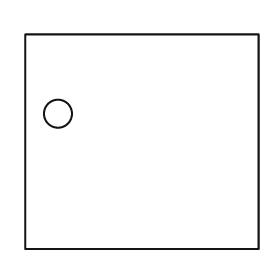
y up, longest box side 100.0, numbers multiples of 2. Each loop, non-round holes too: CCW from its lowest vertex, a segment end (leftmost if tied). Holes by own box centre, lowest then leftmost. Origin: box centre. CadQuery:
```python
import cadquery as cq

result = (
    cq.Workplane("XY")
    .moveTo(-50.0, -46.0)
    .lineTo(50.0, -46.0)
    .lineTo(50.0, 46.0)
    .lineTo(-50.0, 46.0)
    .close()
    .moveTo(-36.0, 12.0)
    .circle(6.0)
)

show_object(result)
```